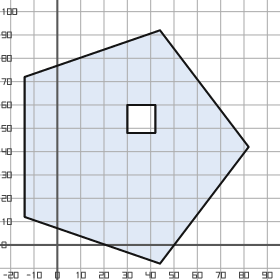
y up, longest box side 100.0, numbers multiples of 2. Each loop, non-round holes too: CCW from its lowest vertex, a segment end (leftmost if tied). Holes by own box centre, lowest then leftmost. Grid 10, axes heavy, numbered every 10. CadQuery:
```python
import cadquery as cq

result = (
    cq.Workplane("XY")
    .moveTo(44.0, -8.0)
    .lineTo(82.0, 42.0)
    .lineTo(44.0, 92.0)
    .lineTo(-14.0, 72.0)
    .lineTo(-14.0, 12.0)
    .close()
    .moveTo(30.0, 48.0)
    .lineTo(42.0, 48.0)
    .lineTo(42.0, 60.0)
    .lineTo(30.0, 60.0)
    .close()
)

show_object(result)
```